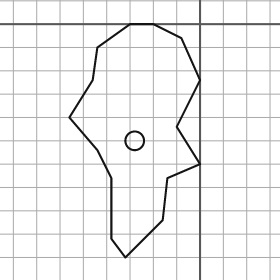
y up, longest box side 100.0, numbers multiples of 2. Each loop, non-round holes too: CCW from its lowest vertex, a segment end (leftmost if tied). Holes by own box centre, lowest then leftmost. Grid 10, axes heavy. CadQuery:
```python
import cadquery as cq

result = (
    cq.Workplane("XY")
    .moveTo(-32.0, -100.0)
    .lineTo(-16.0, -84.0)
    .lineTo(-14.0, -66.0)
    .lineTo(0.0, -60.0)
    .lineTo(-10.0, -44.0)
    .lineTo(0.0, -24.0)
    .lineTo(-8.0, -6.0)
    .lineTo(-20.0, 0.0)
    .lineTo(-30.0, 0.0)
    .lineTo(-44.0, -10.0)
    .lineTo(-46.0, -24.0)
    .lineTo(-56.0, -40.0)
    .lineTo(-44.0, -54.0)
    .lineTo(-38.0, -66.0)
    .lineTo(-38.0, -92.0)
    .close()
    .moveTo(-28.0, -50.0)
    .circle(4.0)
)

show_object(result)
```